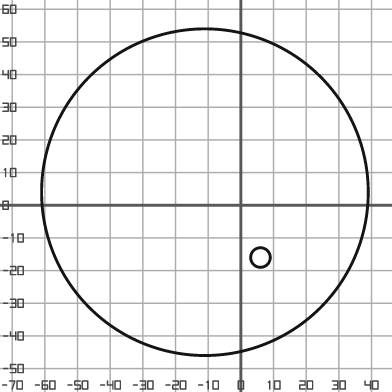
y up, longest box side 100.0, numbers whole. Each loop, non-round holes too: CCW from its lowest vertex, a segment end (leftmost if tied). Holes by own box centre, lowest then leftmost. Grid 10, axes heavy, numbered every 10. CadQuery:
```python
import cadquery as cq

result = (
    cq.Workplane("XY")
    .moveTo(-11.0, 4.0)
    .circle(50.0)
    .moveTo(6.0, -16.0)
    .circle(3.0)
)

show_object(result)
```